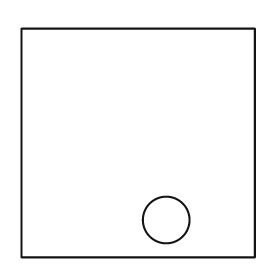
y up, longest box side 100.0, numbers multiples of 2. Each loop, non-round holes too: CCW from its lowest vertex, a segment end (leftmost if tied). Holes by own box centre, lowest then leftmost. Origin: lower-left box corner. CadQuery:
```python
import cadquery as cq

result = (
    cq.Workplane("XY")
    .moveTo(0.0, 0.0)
    .lineTo(100.0, 0.0)
    .lineTo(100.0, 98.0)
    .lineTo(0.0, 98.0)
    .close()
    .moveTo(62.0, 16.0)
    .circle(10.0)
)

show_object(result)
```